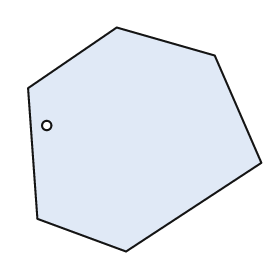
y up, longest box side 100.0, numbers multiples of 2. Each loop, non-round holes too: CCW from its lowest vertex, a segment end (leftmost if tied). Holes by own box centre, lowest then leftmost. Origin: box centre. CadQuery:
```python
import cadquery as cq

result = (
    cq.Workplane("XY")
    .moveTo(-8.0, -48.0)
    .lineTo(50.0, -10.0)
    .lineTo(30.0, 36.0)
    .lineTo(-12.0, 48.0)
    .lineTo(-50.0, 22.0)
    .lineTo(-46.0, -34.0)
    .close()
    .moveTo(-42.0, 6.0)
    .circle(2.0)
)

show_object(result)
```